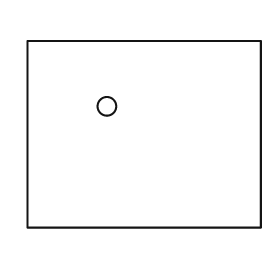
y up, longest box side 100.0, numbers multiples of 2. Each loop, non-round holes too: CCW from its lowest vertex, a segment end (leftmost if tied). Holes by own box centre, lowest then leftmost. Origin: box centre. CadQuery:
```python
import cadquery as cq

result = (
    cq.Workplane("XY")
    .moveTo(-50.0, -40.0)
    .lineTo(50.0, -40.0)
    .lineTo(50.0, 40.0)
    .lineTo(-50.0, 40.0)
    .close()
    .moveTo(-16.0, 12.0)
    .circle(4.0)
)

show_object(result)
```